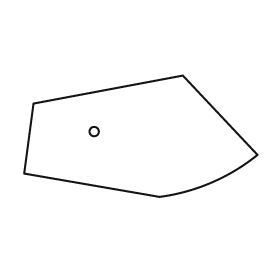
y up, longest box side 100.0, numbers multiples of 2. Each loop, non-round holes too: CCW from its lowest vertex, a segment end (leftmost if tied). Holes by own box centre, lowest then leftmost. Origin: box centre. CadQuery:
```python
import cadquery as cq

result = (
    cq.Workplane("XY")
    .moveTo(8.0, -26.0)
    .threePointArc((30.0, -20.0), (50.0, -8.0))
    .lineTo(18.0, 26.0)
    .lineTo(-46.0, 14.0)
    .lineTo(-50.0, -16.0)
    .close()
    .moveTo(-20.0, 2.0)
    .circle(2.0)
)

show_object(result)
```